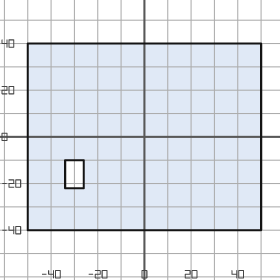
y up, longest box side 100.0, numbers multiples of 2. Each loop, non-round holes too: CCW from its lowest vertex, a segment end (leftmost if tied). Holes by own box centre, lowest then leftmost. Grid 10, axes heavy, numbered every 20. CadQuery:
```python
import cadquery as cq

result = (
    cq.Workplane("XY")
    .moveTo(-50.0, -40.0)
    .lineTo(50.0, -40.0)
    .lineTo(50.0, 40.0)
    .lineTo(-50.0, 40.0)
    .close()
    .moveTo(-34.0, -22.0)
    .lineTo(-26.0, -22.0)
    .lineTo(-26.0, -10.0)
    .lineTo(-34.0, -10.0)
    .close()
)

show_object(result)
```